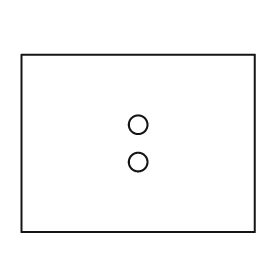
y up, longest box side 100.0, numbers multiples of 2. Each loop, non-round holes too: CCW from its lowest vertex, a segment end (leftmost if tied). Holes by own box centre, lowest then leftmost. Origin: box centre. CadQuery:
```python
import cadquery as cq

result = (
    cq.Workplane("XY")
    .moveTo(-50.0, -38.0)
    .lineTo(50.0, -38.0)
    .lineTo(50.0, 38.0)
    .lineTo(-50.0, 38.0)
    .close()
    .moveTo(0.0, -8.0)
    .circle(4.0)
    .moveTo(0.0, 8.0)
    .circle(4.0)
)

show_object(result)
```